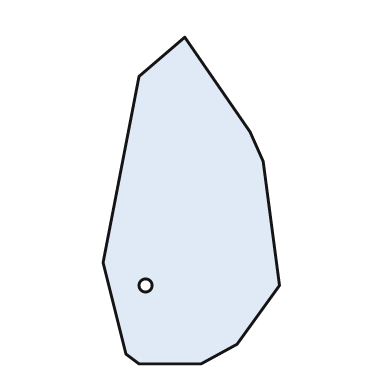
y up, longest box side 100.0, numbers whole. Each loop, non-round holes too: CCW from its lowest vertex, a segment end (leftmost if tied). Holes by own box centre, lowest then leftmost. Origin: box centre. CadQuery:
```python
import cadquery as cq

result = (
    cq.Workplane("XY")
    .moveTo(-16.0, -50.0)
    .lineTo(3.0, -50.0)
    .lineTo(14.0, -44.0)
    .lineTo(27.0, -26.0)
    .lineTo(22.0, 12.0)
    .lineTo(18.0, 21.0)
    .lineTo(-2.0, 50.0)
    .lineTo(-16.0, 38.0)
    .lineTo(-27.0, -19.0)
    .lineTo(-20.0, -47.0)
    .close()
    .moveTo(-14.0, -26.0)
    .circle(2.0)
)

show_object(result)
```